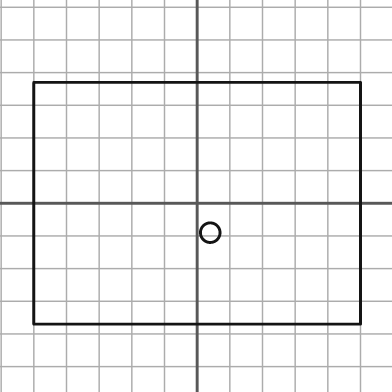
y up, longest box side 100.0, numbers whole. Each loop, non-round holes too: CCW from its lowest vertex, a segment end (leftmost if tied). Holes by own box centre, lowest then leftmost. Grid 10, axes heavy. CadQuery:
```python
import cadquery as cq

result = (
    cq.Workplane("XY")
    .moveTo(-50.0, -37.0)
    .lineTo(50.0, -37.0)
    .lineTo(50.0, 37.0)
    .lineTo(-50.0, 37.0)
    .close()
    .moveTo(4.0, -9.0)
    .circle(3.0)
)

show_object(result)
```